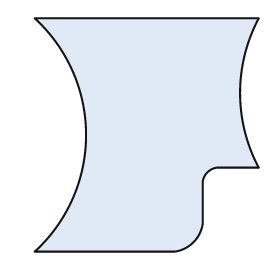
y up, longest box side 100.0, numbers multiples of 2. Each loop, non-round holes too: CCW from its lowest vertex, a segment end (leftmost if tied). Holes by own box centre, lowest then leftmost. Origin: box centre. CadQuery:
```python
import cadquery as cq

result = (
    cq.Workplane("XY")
    .moveTo(-48.0, -50.0)
    .lineTo(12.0, -50.0)
    .threePointArc((20.0, -46.0), (24.0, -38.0))
    .lineTo(24.0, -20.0)
    .threePointArc((26.0, -16.0), (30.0, -14.0))
    .lineTo(48.0, -14.0)
    .threePointArc((40.0, 18.0), (48.0, 50.0))
    .lineTo(-48.0, 50.0)
    .threePointArc((-26.0, 0.0), (-48.0, -50.0))
    .close()
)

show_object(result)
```